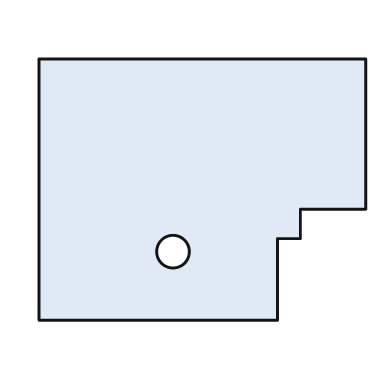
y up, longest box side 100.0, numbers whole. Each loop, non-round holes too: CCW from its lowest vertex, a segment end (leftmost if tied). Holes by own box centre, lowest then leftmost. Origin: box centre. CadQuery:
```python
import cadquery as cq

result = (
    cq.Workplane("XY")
    .moveTo(-50.0, -40.0)
    .lineTo(23.0, -40.0)
    .lineTo(23.0, -15.0)
    .lineTo(30.0, -15.0)
    .lineTo(30.0, -6.0)
    .lineTo(50.0, -6.0)
    .lineTo(50.0, 40.0)
    .lineTo(-50.0, 40.0)
    .close()
    .moveTo(-9.0, -19.0)
    .circle(5.0)
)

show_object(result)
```